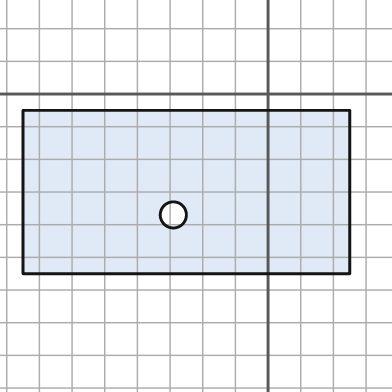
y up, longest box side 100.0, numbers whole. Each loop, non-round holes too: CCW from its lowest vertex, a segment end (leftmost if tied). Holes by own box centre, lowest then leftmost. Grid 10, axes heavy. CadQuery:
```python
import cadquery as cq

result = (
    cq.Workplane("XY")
    .moveTo(-75.0, -55.0)
    .lineTo(25.0, -55.0)
    .lineTo(25.0, -5.0)
    .lineTo(-75.0, -5.0)
    .close()
    .moveTo(-29.0, -37.0)
    .circle(4.0)
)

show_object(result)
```